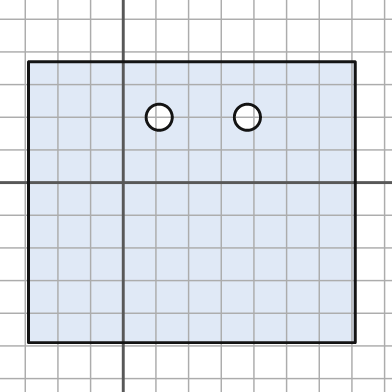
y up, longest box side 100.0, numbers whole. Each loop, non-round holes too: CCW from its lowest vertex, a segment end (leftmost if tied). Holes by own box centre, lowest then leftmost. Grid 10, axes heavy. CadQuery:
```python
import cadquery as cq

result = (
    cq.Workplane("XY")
    .moveTo(-29.0, -49.0)
    .lineTo(71.0, -49.0)
    .lineTo(71.0, 37.0)
    .lineTo(-29.0, 37.0)
    .close()
    .moveTo(11.0, 20.0)
    .circle(4.0)
    .moveTo(38.0, 20.0)
    .circle(4.0)
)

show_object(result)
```